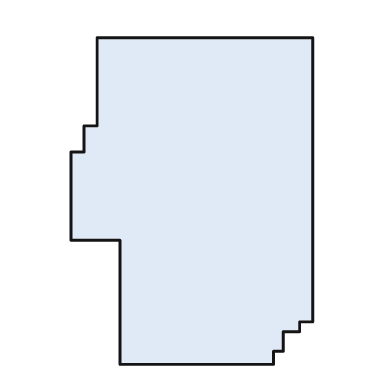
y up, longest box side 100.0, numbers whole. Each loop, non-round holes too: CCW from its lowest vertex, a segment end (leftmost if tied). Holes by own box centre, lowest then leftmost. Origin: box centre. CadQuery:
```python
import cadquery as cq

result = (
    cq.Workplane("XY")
    .moveTo(-22.0, -50.0)
    .lineTo(25.0, -50.0)
    .lineTo(25.0, -46.0)
    .lineTo(28.0, -46.0)
    .lineTo(28.0, -40.0)
    .lineTo(33.0, -40.0)
    .lineTo(33.0, -37.0)
    .lineTo(37.0, -37.0)
    .lineTo(37.0, 50.0)
    .lineTo(-29.0, 50.0)
    .lineTo(-29.0, 23.0)
    .lineTo(-33.0, 23.0)
    .lineTo(-33.0, 15.0)
    .lineTo(-37.0, 15.0)
    .lineTo(-37.0, -12.0)
    .lineTo(-22.0, -12.0)
    .close()
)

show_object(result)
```